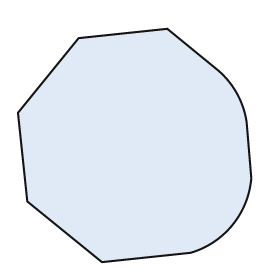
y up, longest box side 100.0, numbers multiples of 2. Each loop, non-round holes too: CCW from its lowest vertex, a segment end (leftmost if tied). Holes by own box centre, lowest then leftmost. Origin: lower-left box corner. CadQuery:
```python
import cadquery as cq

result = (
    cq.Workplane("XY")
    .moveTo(36.0, 0.0)
    .lineTo(74.0, 4.0)
    .threePointArc((92.0, 16.0), (100.0, 36.0))
    .lineTo(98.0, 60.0)
    .threePointArc((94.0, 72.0), (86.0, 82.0))
    .lineTo(64.0, 100.0)
    .lineTo(26.0, 96.0)
    .lineTo(0.0, 64.0)
    .lineTo(4.0, 26.0)
    .close()
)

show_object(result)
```